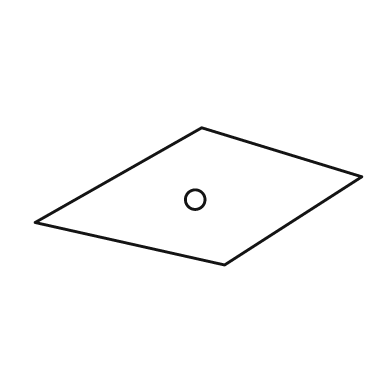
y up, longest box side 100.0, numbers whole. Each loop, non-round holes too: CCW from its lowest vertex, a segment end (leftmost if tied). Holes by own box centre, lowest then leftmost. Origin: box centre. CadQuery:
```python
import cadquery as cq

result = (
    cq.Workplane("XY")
    .moveTo(8.0, -21.0)
    .lineTo(50.0, 6.0)
    .lineTo(1.0, 21.0)
    .lineTo(-50.0, -8.0)
    .close()
    .moveTo(-1.0, -1.0)
    .circle(3.0)
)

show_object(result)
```